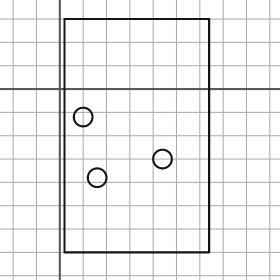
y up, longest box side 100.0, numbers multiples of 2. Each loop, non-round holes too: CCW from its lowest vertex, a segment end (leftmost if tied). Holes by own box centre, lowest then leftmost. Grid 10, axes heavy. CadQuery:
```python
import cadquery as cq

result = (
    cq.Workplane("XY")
    .moveTo(2.0, -70.0)
    .lineTo(64.0, -70.0)
    .lineTo(64.0, 30.0)
    .lineTo(2.0, 30.0)
    .close()
    .moveTo(16.0, -38.0)
    .circle(4.0)
    .moveTo(44.0, -30.0)
    .circle(4.0)
    .moveTo(10.0, -12.0)
    .circle(4.0)
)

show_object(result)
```